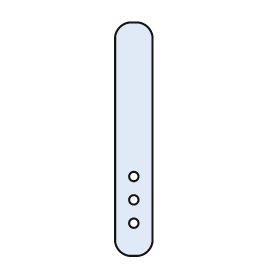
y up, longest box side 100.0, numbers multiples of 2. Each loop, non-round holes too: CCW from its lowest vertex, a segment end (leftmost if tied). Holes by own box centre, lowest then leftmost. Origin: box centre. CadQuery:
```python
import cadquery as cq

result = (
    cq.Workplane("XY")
    .moveTo(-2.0, -50.0)
    .lineTo(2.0, -50.0)
    .threePointArc((6.0, -48.0), (8.0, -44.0))
    .lineTo(8.0, 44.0)
    .threePointArc((6.0, 48.0), (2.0, 50.0))
    .lineTo(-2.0, 50.0)
    .threePointArc((-6.0, 48.0), (-8.0, 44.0))
    .lineTo(-8.0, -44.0)
    .threePointArc((-6.0, -48.0), (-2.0, -50.0))
    .close()
    .moveTo(0.0, -36.0)
    .circle(2.0)
    .moveTo(0.0, -26.0)
    .circle(2.0)
    .moveTo(0.0, -16.0)
    .circle(2.0)
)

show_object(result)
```